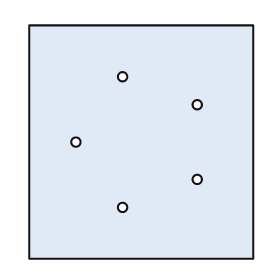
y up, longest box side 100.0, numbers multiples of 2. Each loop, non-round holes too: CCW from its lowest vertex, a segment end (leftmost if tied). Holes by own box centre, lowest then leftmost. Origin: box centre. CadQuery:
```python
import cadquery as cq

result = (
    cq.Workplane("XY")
    .moveTo(-48.0, -50.0)
    .lineTo(48.0, -50.0)
    .lineTo(48.0, 50.0)
    .lineTo(-48.0, 50.0)
    .close()
    .moveTo(-8.0, -28.0)
    .circle(2.0)
    .moveTo(24.0, -16.0)
    .circle(2.0)
    .moveTo(-28.0, 0.0)
    .circle(2.0)
    .moveTo(24.0, 16.0)
    .circle(2.0)
    .moveTo(-8.0, 28.0)
    .circle(2.0)
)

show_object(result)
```